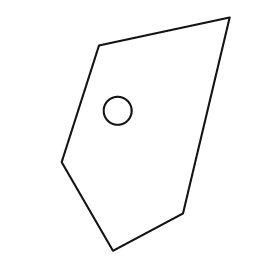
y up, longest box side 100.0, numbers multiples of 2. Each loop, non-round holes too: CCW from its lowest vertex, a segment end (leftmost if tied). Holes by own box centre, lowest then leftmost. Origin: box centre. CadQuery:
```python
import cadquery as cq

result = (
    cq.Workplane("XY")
    .moveTo(-14.0, -50.0)
    .lineTo(16.0, -34.0)
    .lineTo(36.0, 50.0)
    .lineTo(-20.0, 38.0)
    .lineTo(-36.0, -12.0)
    .close()
    .moveTo(-12.0, 10.0)
    .circle(6.0)
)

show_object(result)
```